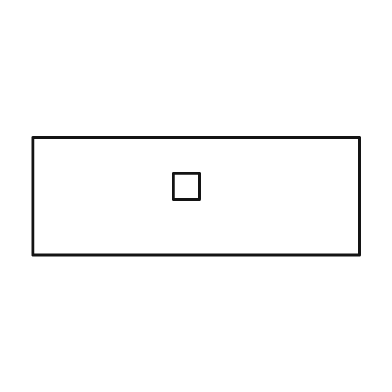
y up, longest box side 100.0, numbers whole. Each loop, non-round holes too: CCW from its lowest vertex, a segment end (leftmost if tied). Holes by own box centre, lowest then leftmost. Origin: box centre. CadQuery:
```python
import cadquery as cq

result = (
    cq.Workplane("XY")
    .moveTo(-50.0, -18.0)
    .lineTo(50.0, -18.0)
    .lineTo(50.0, 18.0)
    .lineTo(-50.0, 18.0)
    .close()
    .moveTo(-7.0, -1.0)
    .lineTo(1.0, -1.0)
    .lineTo(1.0, 7.0)
    .lineTo(-7.0, 7.0)
    .close()
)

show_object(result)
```